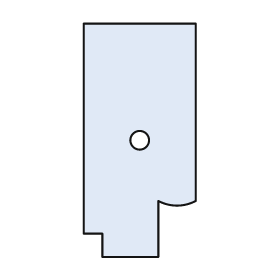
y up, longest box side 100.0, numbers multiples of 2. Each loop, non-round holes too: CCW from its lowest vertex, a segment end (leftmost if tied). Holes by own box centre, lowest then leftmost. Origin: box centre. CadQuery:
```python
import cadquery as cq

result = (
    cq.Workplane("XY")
    .moveTo(-16.0, -50.0)
    .lineTo(8.0, -50.0)
    .lineTo(8.0, -26.0)
    .threePointArc((16.0, -28.0), (24.0, -26.0))
    .lineTo(24.0, 50.0)
    .lineTo(-24.0, 50.0)
    .lineTo(-24.0, -40.0)
    .lineTo(-16.0, -40.0)
    .close()
    .moveTo(0.0, 0.0)
    .circle(4.0)
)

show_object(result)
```